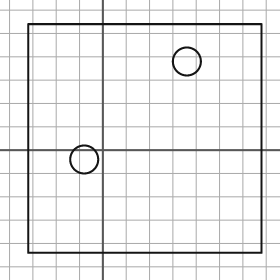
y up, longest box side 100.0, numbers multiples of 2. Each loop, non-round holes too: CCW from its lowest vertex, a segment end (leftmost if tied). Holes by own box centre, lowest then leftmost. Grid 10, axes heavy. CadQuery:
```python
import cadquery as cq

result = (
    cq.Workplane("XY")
    .moveTo(-32.0, -44.0)
    .lineTo(68.0, -44.0)
    .lineTo(68.0, 54.0)
    .lineTo(-32.0, 54.0)
    .close()
    .moveTo(-8.0, -4.0)
    .circle(6.0)
    .moveTo(36.0, 38.0)
    .circle(6.0)
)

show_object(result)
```